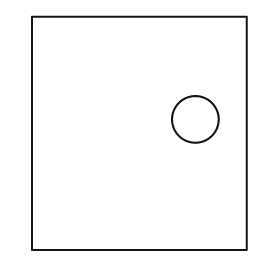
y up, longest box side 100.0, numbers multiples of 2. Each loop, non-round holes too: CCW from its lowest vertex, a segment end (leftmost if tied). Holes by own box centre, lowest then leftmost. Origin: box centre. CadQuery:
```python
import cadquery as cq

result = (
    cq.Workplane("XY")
    .moveTo(-46.0, -50.0)
    .lineTo(46.0, -50.0)
    .lineTo(46.0, 50.0)
    .lineTo(-46.0, 50.0)
    .close()
    .moveTo(24.0, 6.0)
    .circle(10.0)
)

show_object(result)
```